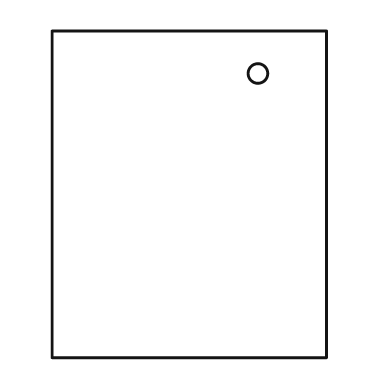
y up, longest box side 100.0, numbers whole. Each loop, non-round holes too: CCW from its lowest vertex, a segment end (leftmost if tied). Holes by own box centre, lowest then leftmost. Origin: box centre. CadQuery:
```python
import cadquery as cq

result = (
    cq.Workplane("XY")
    .moveTo(-42.0, -50.0)
    .lineTo(42.0, -50.0)
    .lineTo(42.0, 50.0)
    .lineTo(-42.0, 50.0)
    .close()
    .moveTo(21.0, 37.0)
    .circle(3.0)
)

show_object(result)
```